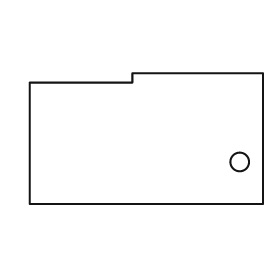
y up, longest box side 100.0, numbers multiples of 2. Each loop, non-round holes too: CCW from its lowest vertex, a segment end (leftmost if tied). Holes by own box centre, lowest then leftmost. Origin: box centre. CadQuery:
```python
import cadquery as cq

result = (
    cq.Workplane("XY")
    .moveTo(-50.0, -28.0)
    .lineTo(50.0, -28.0)
    .lineTo(50.0, 28.0)
    .lineTo(-6.0, 28.0)
    .lineTo(-6.0, 24.0)
    .lineTo(-50.0, 24.0)
    .close()
    .moveTo(40.0, -10.0)
    .circle(4.0)
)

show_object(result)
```